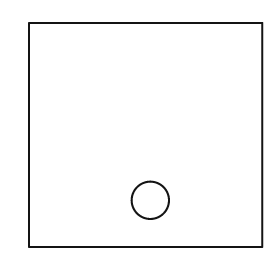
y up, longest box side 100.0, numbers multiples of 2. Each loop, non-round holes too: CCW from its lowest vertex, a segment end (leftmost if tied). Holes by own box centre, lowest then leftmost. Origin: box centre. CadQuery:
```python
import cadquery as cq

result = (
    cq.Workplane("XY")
    .moveTo(-50.0, -48.0)
    .lineTo(50.0, -48.0)
    .lineTo(50.0, 48.0)
    .lineTo(-50.0, 48.0)
    .close()
    .moveTo(2.0, -28.0)
    .circle(8.0)
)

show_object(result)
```